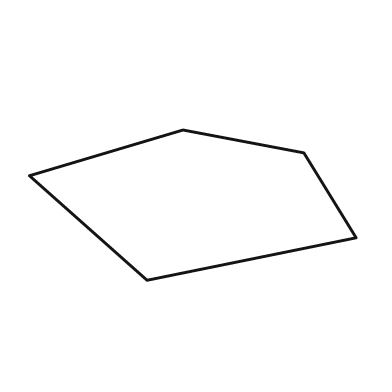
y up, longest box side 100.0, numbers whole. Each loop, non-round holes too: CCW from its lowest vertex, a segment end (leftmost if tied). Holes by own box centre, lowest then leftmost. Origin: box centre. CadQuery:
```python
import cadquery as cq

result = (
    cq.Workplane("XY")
    .moveTo(-14.0, -23.0)
    .lineTo(50.0, -10.0)
    .lineTo(34.0, 16.0)
    .lineTo(-3.0, 23.0)
    .lineTo(-50.0, 9.0)
    .close()
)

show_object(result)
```